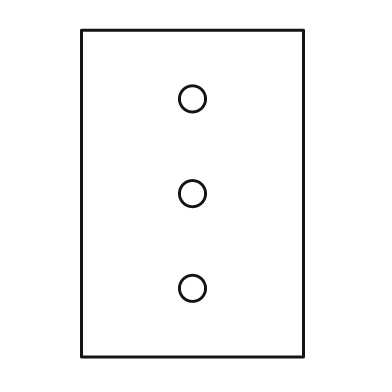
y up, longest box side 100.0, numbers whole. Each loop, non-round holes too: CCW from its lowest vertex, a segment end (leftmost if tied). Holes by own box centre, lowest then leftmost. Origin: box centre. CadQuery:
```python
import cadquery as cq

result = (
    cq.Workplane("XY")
    .moveTo(-34.0, -50.0)
    .lineTo(34.0, -50.0)
    .lineTo(34.0, 50.0)
    .lineTo(-34.0, 50.0)
    .close()
    .moveTo(0.0, -29.0)
    .circle(4.0)
    .moveTo(0.0, 0.0)
    .circle(4.0)
    .moveTo(0.0, 29.0)
    .circle(4.0)
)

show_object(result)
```